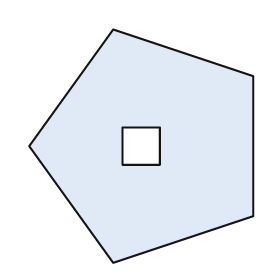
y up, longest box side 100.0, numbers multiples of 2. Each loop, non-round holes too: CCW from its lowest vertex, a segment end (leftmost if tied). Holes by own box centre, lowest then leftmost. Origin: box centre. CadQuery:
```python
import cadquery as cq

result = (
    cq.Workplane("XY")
    .moveTo(-12.0, -50.0)
    .lineTo(48.0, -30.0)
    .lineTo(48.0, 30.0)
    .lineTo(-12.0, 50.0)
    .lineTo(-48.0, 0.0)
    .close()
    .moveTo(-8.0, -8.0)
    .lineTo(8.0, -8.0)
    .lineTo(8.0, 8.0)
    .lineTo(-8.0, 8.0)
    .close()
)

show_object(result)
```